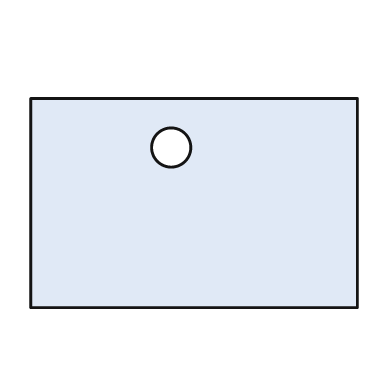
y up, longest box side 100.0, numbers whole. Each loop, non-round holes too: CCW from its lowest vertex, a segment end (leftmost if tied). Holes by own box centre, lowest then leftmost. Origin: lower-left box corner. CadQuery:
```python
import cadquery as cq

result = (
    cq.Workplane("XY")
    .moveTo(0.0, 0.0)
    .lineTo(100.0, 0.0)
    .lineTo(100.0, 64.0)
    .lineTo(0.0, 64.0)
    .close()
    .moveTo(43.0, 49.0)
    .circle(6.0)
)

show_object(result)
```